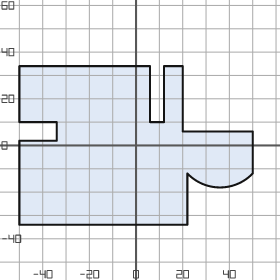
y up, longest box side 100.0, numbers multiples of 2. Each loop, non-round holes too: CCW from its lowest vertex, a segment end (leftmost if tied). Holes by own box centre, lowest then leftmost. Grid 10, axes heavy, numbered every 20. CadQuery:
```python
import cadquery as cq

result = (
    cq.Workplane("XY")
    .moveTo(-50.0, -34.0)
    .lineTo(22.0, -34.0)
    .lineTo(22.0, -12.0)
    .threePointArc((36.0, -18.0), (50.0, -12.0))
    .lineTo(50.0, 6.0)
    .lineTo(20.0, 6.0)
    .lineTo(20.0, 34.0)
    .lineTo(12.0, 34.0)
    .lineTo(12.0, 10.0)
    .lineTo(6.0, 10.0)
    .lineTo(6.0, 34.0)
    .lineTo(-50.0, 34.0)
    .lineTo(-50.0, 10.0)
    .lineTo(-34.0, 10.0)
    .lineTo(-34.0, 2.0)
    .lineTo(-50.0, 2.0)
    .close()
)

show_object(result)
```